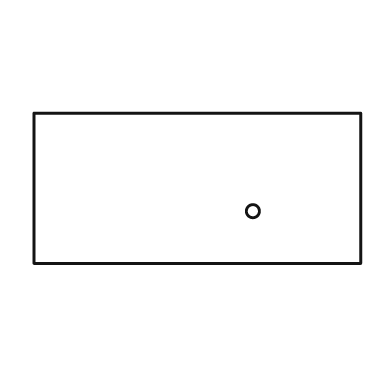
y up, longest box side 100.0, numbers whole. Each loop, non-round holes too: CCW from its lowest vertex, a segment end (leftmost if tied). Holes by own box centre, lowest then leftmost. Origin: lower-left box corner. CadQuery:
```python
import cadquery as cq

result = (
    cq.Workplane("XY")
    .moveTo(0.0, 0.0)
    .lineTo(100.0, 0.0)
    .lineTo(100.0, 46.0)
    .lineTo(0.0, 46.0)
    .close()
    .moveTo(67.0, 16.0)
    .circle(2.0)
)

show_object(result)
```